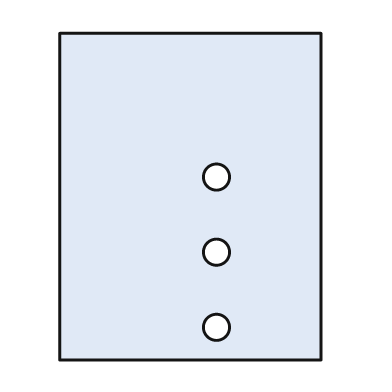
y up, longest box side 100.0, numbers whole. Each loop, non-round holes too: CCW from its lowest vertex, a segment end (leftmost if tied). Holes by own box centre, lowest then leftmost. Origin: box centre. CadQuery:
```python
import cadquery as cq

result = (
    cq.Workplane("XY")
    .moveTo(-40.0, -50.0)
    .lineTo(40.0, -50.0)
    .lineTo(40.0, 50.0)
    .lineTo(-40.0, 50.0)
    .close()
    .moveTo(8.0, -40.0)
    .circle(4.0)
    .moveTo(8.0, -17.0)
    .circle(4.0)
    .moveTo(8.0, 6.0)
    .circle(4.0)
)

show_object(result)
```